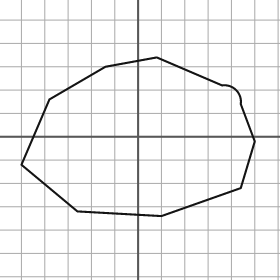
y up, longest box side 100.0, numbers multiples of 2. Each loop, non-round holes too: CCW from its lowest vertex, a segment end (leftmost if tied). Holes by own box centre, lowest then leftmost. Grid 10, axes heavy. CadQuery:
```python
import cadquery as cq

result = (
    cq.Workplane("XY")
    .moveTo(10.0, -34.0)
    .lineTo(44.0, -22.0)
    .lineTo(50.0, -2.0)
    .lineTo(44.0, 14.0)
    .threePointArc((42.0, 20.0), (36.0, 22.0))
    .lineTo(8.0, 34.0)
    .lineTo(-14.0, 30.0)
    .lineTo(-38.0, 16.0)
    .lineTo(-50.0, -12.0)
    .lineTo(-26.0, -32.0)
    .close()
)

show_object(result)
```